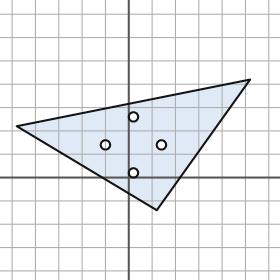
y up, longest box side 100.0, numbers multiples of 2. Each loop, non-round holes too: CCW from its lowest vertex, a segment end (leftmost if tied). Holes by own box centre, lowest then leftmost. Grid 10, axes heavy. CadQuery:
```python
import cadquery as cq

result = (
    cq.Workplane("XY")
    .moveTo(12.0, -14.0)
    .lineTo(52.0, 42.0)
    .lineTo(-48.0, 22.0)
    .close()
    .moveTo(2.0, 2.0)
    .circle(2.0)
    .moveTo(-10.0, 14.0)
    .circle(2.0)
    .moveTo(14.0, 14.0)
    .circle(2.0)
    .moveTo(2.0, 26.0)
    .circle(2.0)
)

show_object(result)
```